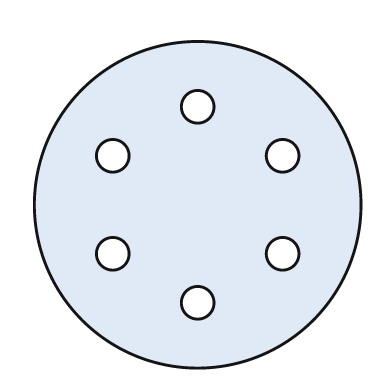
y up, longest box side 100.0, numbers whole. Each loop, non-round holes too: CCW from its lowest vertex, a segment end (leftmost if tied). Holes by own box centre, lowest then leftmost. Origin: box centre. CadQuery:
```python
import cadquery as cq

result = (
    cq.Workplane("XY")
    .moveTo(0.0, 0.0)
    .circle(50.0)
    .moveTo(0.0, -30.0)
    .circle(5.0)
    .moveTo(-26.0, -15.0)
    .circle(5.0)
    .moveTo(26.0, -15.0)
    .circle(5.0)
    .moveTo(-26.0, 15.0)
    .circle(5.0)
    .moveTo(26.0, 15.0)
    .circle(5.0)
    .moveTo(0.0, 30.0)
    .circle(5.0)
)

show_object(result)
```